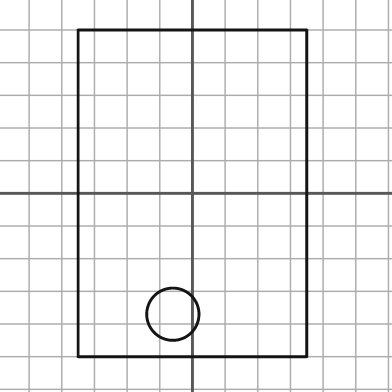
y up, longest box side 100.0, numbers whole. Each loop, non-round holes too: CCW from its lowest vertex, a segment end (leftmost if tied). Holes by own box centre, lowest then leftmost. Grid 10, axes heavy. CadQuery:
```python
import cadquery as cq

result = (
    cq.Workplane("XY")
    .moveTo(-35.0, -50.0)
    .lineTo(35.0, -50.0)
    .lineTo(35.0, 50.0)
    .lineTo(-35.0, 50.0)
    .close()
    .moveTo(-6.0, -37.0)
    .circle(8.0)
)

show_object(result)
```